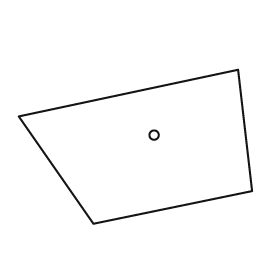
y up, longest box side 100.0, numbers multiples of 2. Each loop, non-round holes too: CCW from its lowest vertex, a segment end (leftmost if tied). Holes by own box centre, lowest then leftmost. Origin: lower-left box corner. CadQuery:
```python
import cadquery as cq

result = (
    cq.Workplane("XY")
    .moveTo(32.0, 0.0)
    .lineTo(100.0, 14.0)
    .lineTo(94.0, 66.0)
    .lineTo(0.0, 46.0)
    .close()
    .moveTo(58.0, 38.0)
    .circle(2.0)
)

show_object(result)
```